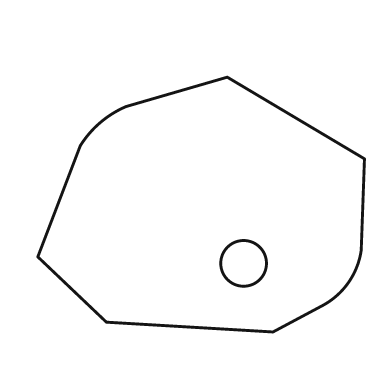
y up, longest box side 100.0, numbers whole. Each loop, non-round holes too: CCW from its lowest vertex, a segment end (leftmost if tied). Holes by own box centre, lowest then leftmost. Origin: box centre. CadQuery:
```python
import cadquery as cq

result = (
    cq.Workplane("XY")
    .moveTo(22.0, -39.0)
    .lineTo(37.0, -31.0)
    .threePointArc((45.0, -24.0), (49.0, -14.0))
    .lineTo(50.0, 14.0)
    .lineTo(8.0, 39.0)
    .lineTo(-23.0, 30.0)
    .threePointArc((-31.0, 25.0), (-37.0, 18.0))
    .lineTo(-50.0, -16.0)
    .lineTo(-29.0, -36.0)
    .close()
    .moveTo(13.0, -18.0)
    .circle(7.0)
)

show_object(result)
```